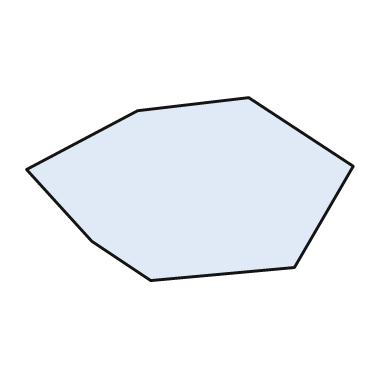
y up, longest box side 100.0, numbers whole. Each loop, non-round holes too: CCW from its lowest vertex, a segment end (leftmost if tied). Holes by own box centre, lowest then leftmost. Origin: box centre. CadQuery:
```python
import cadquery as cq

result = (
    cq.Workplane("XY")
    .moveTo(-12.0, -28.0)
    .lineTo(32.0, -24.0)
    .lineTo(50.0, 7.0)
    .lineTo(18.0, 28.0)
    .lineTo(-16.0, 24.0)
    .lineTo(-50.0, 6.0)
    .lineTo(-30.0, -16.0)
    .close()
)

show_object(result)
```